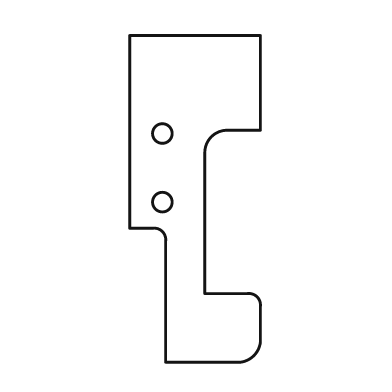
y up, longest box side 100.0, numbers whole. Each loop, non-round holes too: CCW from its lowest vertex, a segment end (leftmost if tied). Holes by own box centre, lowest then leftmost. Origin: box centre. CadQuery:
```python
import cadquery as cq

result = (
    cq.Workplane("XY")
    .moveTo(-9.0, -50.0)
    .lineTo(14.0, -50.0)
    .threePointArc((18.0, -48.0), (20.0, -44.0))
    .lineTo(20.0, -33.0)
    .threePointArc((19.0, -30.0), (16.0, -29.0))
    .lineTo(3.0, -29.0)
    .lineTo(3.0, 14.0)
    .threePointArc((5.0, 19.0), (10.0, 21.0))
    .lineTo(20.0, 21.0)
    .lineTo(20.0, 50.0)
    .lineTo(-20.0, 50.0)
    .lineTo(-20.0, -9.0)
    .lineTo(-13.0, -9.0)
    .threePointArc((-10.0, -10.0), (-9.0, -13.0))
    .close()
    .moveTo(-10.0, -1.0)
    .circle(3.0)
    .moveTo(-10.0, 20.0)
    .circle(3.0)
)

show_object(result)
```